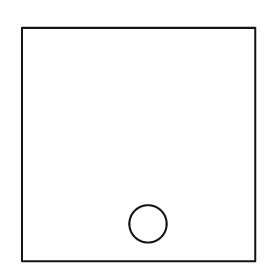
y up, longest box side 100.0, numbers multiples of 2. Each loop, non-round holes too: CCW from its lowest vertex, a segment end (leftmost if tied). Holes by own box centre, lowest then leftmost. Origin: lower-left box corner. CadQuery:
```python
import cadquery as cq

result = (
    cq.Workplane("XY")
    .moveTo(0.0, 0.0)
    .lineTo(100.0, 0.0)
    .lineTo(100.0, 100.0)
    .lineTo(0.0, 100.0)
    .close()
    .moveTo(54.0, 16.0)
    .circle(8.0)
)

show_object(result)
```